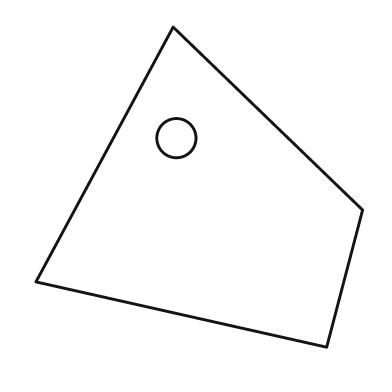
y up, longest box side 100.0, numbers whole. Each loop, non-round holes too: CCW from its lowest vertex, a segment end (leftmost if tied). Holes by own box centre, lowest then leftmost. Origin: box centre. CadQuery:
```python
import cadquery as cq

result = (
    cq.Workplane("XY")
    .moveTo(39.0, -49.0)
    .lineTo(50.0, -7.0)
    .lineTo(-8.0, 49.0)
    .lineTo(-50.0, -29.0)
    .close()
    .moveTo(-7.0, 15.0)
    .circle(6.0)
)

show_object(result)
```